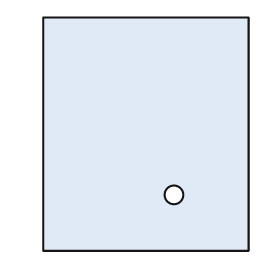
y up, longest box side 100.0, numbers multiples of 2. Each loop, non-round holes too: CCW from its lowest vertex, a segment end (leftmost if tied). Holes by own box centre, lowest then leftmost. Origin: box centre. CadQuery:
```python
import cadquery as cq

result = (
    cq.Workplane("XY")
    .moveTo(-44.0, -50.0)
    .lineTo(44.0, -50.0)
    .lineTo(44.0, 50.0)
    .lineTo(-44.0, 50.0)
    .close()
    .moveTo(12.0, -26.0)
    .circle(4.0)
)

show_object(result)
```